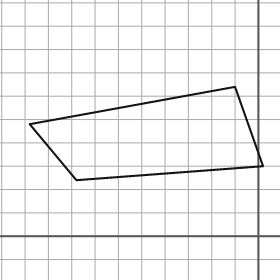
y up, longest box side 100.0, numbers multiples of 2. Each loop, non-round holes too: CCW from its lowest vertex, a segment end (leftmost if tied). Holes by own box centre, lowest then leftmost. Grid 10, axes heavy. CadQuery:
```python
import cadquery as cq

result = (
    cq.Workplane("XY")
    .moveTo(-78.0, 24.0)
    .lineTo(2.0, 30.0)
    .lineTo(-10.0, 64.0)
    .lineTo(-98.0, 48.0)
    .close()
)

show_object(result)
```